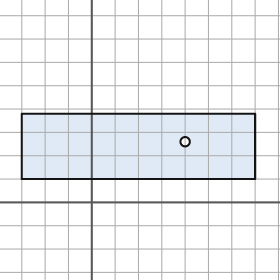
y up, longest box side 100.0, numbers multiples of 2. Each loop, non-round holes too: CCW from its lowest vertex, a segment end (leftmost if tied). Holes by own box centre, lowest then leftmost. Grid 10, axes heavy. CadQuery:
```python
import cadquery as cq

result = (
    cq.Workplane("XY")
    .moveTo(-30.0, 10.0)
    .lineTo(70.0, 10.0)
    .lineTo(70.0, 38.0)
    .lineTo(-30.0, 38.0)
    .close()
    .moveTo(40.0, 26.0)
    .circle(2.0)
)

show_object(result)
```